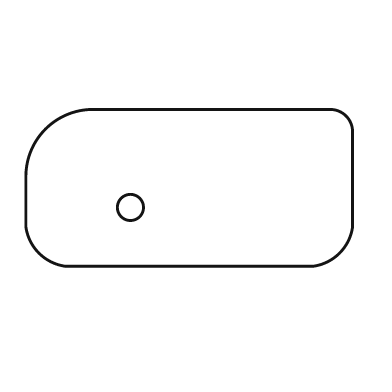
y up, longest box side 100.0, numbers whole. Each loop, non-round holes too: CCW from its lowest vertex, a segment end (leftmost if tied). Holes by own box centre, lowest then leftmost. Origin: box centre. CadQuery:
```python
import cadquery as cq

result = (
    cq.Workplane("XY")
    .moveTo(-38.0, -24.0)
    .lineTo(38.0, -24.0)
    .threePointArc((46.0, -20.0), (50.0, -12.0))
    .lineTo(50.0, 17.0)
    .threePointArc((48.0, 22.0), (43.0, 24.0))
    .lineTo(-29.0, 24.0)
    .threePointArc((-44.0, 18.0), (-50.0, 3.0))
    .lineTo(-50.0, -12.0)
    .threePointArc((-46.0, -20.0), (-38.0, -24.0))
    .close()
    .moveTo(-18.0, -6.0)
    .circle(4.0)
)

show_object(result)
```